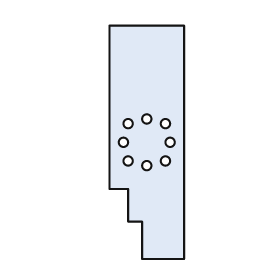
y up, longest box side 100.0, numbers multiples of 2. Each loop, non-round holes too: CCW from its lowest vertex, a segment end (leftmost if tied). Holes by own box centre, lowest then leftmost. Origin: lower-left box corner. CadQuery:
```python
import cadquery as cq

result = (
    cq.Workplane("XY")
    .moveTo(14.0, 0.0)
    .lineTo(32.0, 0.0)
    .lineTo(32.0, 100.0)
    .lineTo(0.0, 100.0)
    .lineTo(0.0, 30.0)
    .lineTo(8.0, 30.0)
    .lineTo(8.0, 16.0)
    .lineTo(14.0, 16.0)
    .close()
    .moveTo(16.0, 40.0)
    .circle(2.0)
    .moveTo(8.0, 42.0)
    .circle(2.0)
    .moveTo(24.0, 42.0)
    .circle(2.0)
    .moveTo(6.0, 50.0)
    .circle(2.0)
    .moveTo(26.0, 50.0)
    .circle(2.0)
    .moveTo(8.0, 58.0)
    .circle(2.0)
    .moveTo(24.0, 58.0)
    .circle(2.0)
    .moveTo(16.0, 60.0)
    .circle(2.0)
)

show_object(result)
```